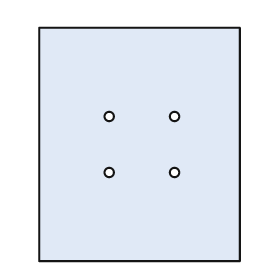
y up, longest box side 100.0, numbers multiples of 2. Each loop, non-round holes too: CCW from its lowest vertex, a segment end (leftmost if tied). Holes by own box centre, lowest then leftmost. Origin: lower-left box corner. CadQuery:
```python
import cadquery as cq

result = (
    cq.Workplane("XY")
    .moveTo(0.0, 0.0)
    .lineTo(86.0, 0.0)
    .lineTo(86.0, 100.0)
    .lineTo(0.0, 100.0)
    .close()
    .moveTo(30.0, 38.0)
    .circle(2.0)
    .moveTo(58.0, 38.0)
    .circle(2.0)
    .moveTo(30.0, 62.0)
    .circle(2.0)
    .moveTo(58.0, 62.0)
    .circle(2.0)
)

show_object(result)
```